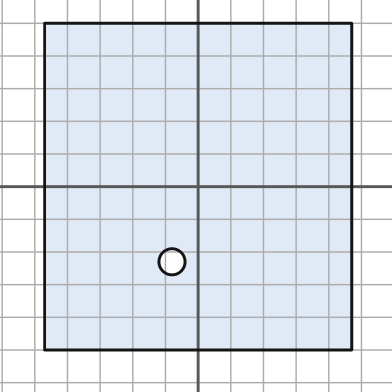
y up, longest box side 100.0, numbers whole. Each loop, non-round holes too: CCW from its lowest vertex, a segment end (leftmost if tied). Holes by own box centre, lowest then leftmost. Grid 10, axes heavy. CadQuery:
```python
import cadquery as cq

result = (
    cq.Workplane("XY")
    .moveTo(-47.0, -50.0)
    .lineTo(47.0, -50.0)
    .lineTo(47.0, 50.0)
    .lineTo(-47.0, 50.0)
    .close()
    .moveTo(-8.0, -23.0)
    .circle(4.0)
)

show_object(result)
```